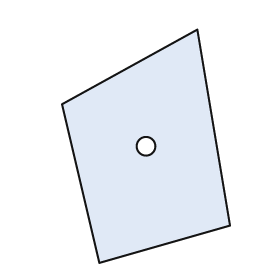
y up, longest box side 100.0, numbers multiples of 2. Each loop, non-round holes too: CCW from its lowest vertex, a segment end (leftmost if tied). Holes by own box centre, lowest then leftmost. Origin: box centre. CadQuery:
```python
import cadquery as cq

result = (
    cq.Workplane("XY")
    .moveTo(-20.0, -50.0)
    .lineTo(36.0, -34.0)
    .lineTo(22.0, 50.0)
    .lineTo(-36.0, 18.0)
    .close()
    .moveTo(0.0, 0.0)
    .circle(4.0)
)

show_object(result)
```